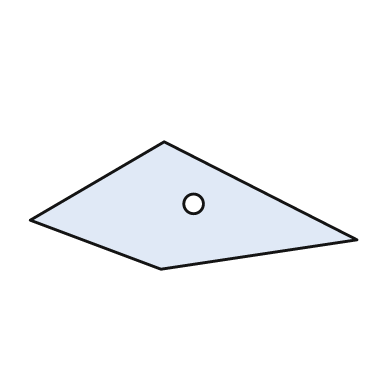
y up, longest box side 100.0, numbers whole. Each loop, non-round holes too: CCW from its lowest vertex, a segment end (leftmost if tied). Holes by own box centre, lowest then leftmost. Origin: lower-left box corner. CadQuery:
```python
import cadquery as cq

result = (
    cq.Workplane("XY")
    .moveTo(40.0, 0.0)
    .lineTo(100.0, 9.0)
    .lineTo(41.0, 39.0)
    .lineTo(0.0, 15.0)
    .close()
    .moveTo(50.0, 20.0)
    .circle(3.0)
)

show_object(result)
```